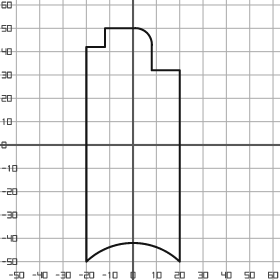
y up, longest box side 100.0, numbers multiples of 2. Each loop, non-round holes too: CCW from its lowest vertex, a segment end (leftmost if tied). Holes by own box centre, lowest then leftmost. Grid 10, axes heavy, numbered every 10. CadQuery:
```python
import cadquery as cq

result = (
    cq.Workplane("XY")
    .moveTo(-20.0, -50.0)
    .threePointArc((0.0, -42.0), (20.0, -50.0))
    .lineTo(20.0, 32.0)
    .lineTo(8.0, 32.0)
    .lineTo(8.0, 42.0)
    .threePointArc((6.0, 48.0), (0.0, 50.0))
    .lineTo(-12.0, 50.0)
    .lineTo(-12.0, 42.0)
    .lineTo(-20.0, 42.0)
    .close()
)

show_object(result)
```